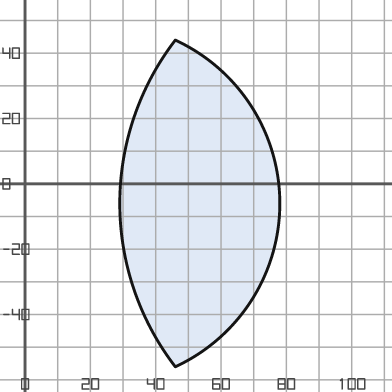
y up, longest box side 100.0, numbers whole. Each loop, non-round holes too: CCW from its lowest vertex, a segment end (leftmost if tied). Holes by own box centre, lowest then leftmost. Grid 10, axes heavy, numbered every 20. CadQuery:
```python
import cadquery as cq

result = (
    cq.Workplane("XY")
    .moveTo(46.0, -56.0)
    .threePointArc((78.0, -6.0), (46.0, 44.0))
    .threePointArc((29.0, -6.0), (46.0, -56.0))
    .close()
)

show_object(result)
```